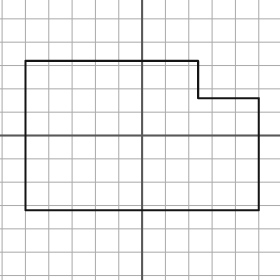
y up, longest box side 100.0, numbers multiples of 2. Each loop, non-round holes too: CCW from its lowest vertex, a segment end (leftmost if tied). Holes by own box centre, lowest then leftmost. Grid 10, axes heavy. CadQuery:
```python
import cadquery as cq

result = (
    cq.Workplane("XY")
    .moveTo(-50.0, -32.0)
    .lineTo(50.0, -32.0)
    .lineTo(50.0, 16.0)
    .lineTo(24.0, 16.0)
    .lineTo(24.0, 32.0)
    .lineTo(-50.0, 32.0)
    .close()
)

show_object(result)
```